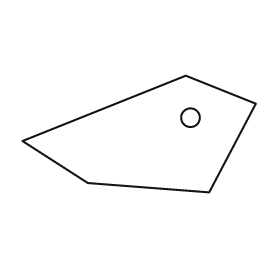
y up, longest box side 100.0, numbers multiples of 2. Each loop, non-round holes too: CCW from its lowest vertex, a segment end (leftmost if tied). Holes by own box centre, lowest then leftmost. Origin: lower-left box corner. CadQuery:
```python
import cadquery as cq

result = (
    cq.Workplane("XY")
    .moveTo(80.0, 0.0)
    .lineTo(100.0, 38.0)
    .lineTo(70.0, 50.0)
    .lineTo(0.0, 22.0)
    .lineTo(28.0, 4.0)
    .close()
    .moveTo(72.0, 32.0)
    .circle(4.0)
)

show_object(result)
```